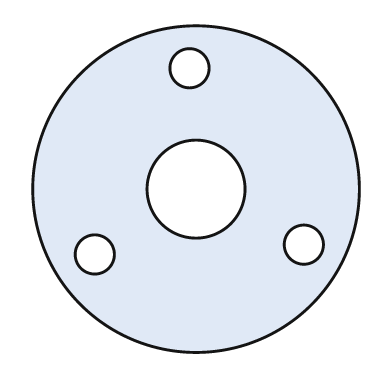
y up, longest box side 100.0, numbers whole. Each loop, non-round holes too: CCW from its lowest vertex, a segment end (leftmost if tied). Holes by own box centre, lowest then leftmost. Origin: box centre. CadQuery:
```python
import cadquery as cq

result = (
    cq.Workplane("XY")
    .moveTo(0.0, 0.0)
    .circle(50.0)
    .moveTo(-31.0, -20.0)
    .circle(6.0)
    .moveTo(33.0, -17.0)
    .circle(6.0)
    .moveTo(0.0, 0.0)
    .circle(15.0)
    .moveTo(-2.0, 37.0)
    .circle(6.0)
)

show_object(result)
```